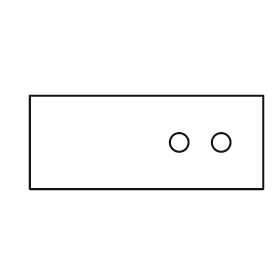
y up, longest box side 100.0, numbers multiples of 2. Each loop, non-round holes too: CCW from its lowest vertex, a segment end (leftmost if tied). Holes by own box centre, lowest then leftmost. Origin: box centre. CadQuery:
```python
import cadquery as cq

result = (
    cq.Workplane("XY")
    .moveTo(-50.0, -20.0)
    .lineTo(50.0, -20.0)
    .lineTo(50.0, 20.0)
    .lineTo(-50.0, 20.0)
    .close()
    .moveTo(14.0, 0.0)
    .circle(4.0)
    .moveTo(32.0, 0.0)
    .circle(4.0)
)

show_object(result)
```